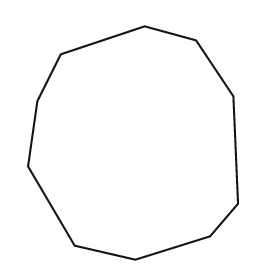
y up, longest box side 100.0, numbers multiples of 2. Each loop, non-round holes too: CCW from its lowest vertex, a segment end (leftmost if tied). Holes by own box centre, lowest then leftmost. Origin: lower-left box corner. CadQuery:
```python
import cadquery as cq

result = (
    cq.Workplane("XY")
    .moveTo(46.0, 0.0)
    .lineTo(78.0, 10.0)
    .lineTo(90.0, 24.0)
    .lineTo(88.0, 70.0)
    .lineTo(72.0, 94.0)
    .lineTo(50.0, 100.0)
    .lineTo(14.0, 88.0)
    .lineTo(4.0, 68.0)
    .lineTo(0.0, 40.0)
    .lineTo(20.0, 6.0)
    .close()
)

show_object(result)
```